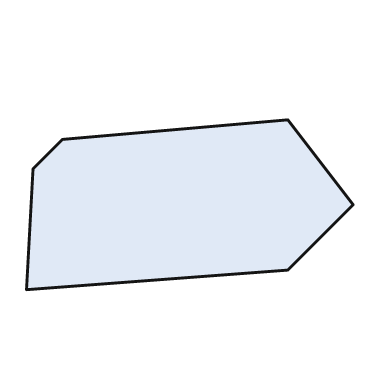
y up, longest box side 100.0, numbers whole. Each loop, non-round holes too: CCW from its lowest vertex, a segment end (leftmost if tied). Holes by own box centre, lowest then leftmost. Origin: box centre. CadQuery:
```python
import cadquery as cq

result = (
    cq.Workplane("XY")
    .moveTo(-50.0, -26.0)
    .lineTo(30.0, -20.0)
    .lineTo(50.0, 0.0)
    .lineTo(30.0, 26.0)
    .lineTo(-39.0, 20.0)
    .lineTo(-48.0, 11.0)
    .close()
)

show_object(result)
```